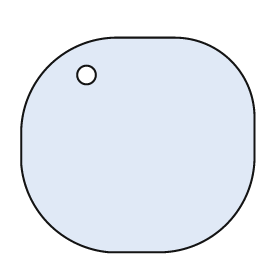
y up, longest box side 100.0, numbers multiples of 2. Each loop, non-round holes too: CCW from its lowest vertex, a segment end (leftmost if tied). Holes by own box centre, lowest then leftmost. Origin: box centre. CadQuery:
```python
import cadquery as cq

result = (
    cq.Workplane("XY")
    .moveTo(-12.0, -46.0)
    .lineTo(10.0, -46.0)
    .threePointArc((38.0, -34.0), (50.0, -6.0))
    .lineTo(50.0, 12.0)
    .threePointArc((40.0, 36.0), (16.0, 46.0))
    .lineTo(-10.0, 46.0)
    .threePointArc((-38.0, 34.0), (-50.0, 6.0))
    .lineTo(-50.0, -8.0)
    .threePointArc((-38.0, -34.0), (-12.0, -46.0))
    .close()
    .moveTo(-22.0, 30.0)
    .circle(4.0)
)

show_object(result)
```